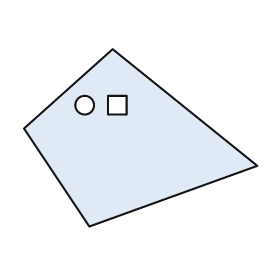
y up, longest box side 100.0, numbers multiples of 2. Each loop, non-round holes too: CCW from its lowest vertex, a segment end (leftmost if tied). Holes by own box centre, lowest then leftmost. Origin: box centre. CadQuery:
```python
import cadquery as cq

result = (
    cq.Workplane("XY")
    .moveTo(-22.0, -38.0)
    .lineTo(50.0, -12.0)
    .lineTo(-12.0, 38.0)
    .lineTo(-50.0, 4.0)
    .close()
    .moveTo(-24.0, 14.0)
    .circle(4.0)
    .moveTo(-14.0, 10.0)
    .lineTo(-6.0, 10.0)
    .lineTo(-6.0, 18.0)
    .lineTo(-14.0, 18.0)
    .close()
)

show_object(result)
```